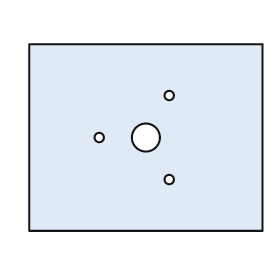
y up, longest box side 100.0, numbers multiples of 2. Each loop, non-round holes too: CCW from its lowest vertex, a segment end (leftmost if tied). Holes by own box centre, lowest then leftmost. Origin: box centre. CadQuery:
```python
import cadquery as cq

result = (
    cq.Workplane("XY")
    .moveTo(-50.0, -40.0)
    .lineTo(50.0, -40.0)
    .lineTo(50.0, 40.0)
    .lineTo(-50.0, 40.0)
    .close()
    .moveTo(10.0, -18.0)
    .circle(2.0)
    .moveTo(-20.0, 0.0)
    .circle(2.0)
    .moveTo(0.0, 0.0)
    .circle(6.0)
    .moveTo(10.0, 18.0)
    .circle(2.0)
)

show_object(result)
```